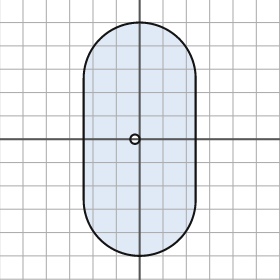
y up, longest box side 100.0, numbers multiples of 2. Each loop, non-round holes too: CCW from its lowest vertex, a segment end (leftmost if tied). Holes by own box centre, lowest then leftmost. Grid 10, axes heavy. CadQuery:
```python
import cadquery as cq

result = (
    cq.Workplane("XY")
    .moveTo(-24.0, -26.0)
    .threePointArc((0.0, -50.0), (24.0, -26.0))
    .lineTo(24.0, 26.0)
    .threePointArc((0.0, 50.0), (-24.0, 26.0))
    .close()
    .moveTo(-2.0, 0.0)
    .circle(2.0)
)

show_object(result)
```